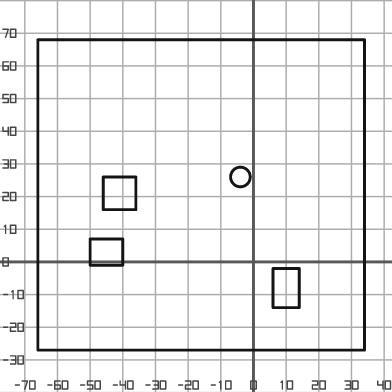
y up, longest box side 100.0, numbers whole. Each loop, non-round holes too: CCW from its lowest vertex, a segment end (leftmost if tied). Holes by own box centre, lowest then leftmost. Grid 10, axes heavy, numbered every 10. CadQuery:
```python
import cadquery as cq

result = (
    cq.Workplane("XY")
    .moveTo(-66.0, -27.0)
    .lineTo(34.0, -27.0)
    .lineTo(34.0, 68.0)
    .lineTo(-66.0, 68.0)
    .close()
    .moveTo(6.0, -14.0)
    .lineTo(14.0, -14.0)
    .lineTo(14.0, -2.0)
    .lineTo(6.0, -2.0)
    .close()
    .moveTo(-50.0, -1.0)
    .lineTo(-40.0, -1.0)
    .lineTo(-40.0, 7.0)
    .lineTo(-50.0, 7.0)
    .close()
    .moveTo(-46.0, 16.0)
    .lineTo(-36.0, 16.0)
    .lineTo(-36.0, 26.0)
    .lineTo(-46.0, 26.0)
    .close()
    .moveTo(-4.0, 26.0)
    .circle(3.0)
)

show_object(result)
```